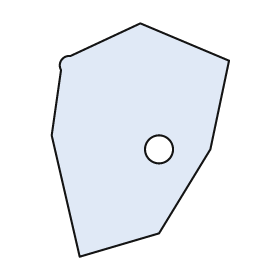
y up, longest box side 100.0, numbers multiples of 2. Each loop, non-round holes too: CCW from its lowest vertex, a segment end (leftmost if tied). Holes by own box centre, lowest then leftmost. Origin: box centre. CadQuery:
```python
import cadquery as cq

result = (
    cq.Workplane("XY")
    .moveTo(-26.0, -50.0)
    .lineTo(8.0, -40.0)
    .lineTo(30.0, -4.0)
    .lineTo(38.0, 34.0)
    .lineTo(0.0, 50.0)
    .lineTo(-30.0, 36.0)
    .threePointArc((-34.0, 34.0), (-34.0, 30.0))
    .lineTo(-38.0, 2.0)
    .close()
    .moveTo(8.0, -4.0)
    .circle(6.0)
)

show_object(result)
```